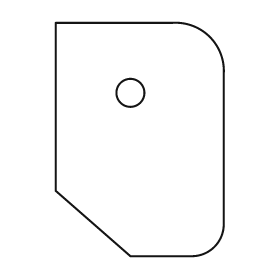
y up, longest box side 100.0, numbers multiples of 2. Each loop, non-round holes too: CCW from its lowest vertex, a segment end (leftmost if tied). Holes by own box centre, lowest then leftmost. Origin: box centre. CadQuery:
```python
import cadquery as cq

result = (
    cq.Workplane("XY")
    .moveTo(-4.0, -50.0)
    .lineTo(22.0, -50.0)
    .threePointArc((32.0, -46.0), (36.0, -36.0))
    .lineTo(36.0, 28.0)
    .threePointArc((30.0, 44.0), (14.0, 50.0))
    .lineTo(-36.0, 50.0)
    .lineTo(-36.0, -22.0)
    .close()
    .moveTo(-4.0, 20.0)
    .circle(6.0)
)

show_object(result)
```